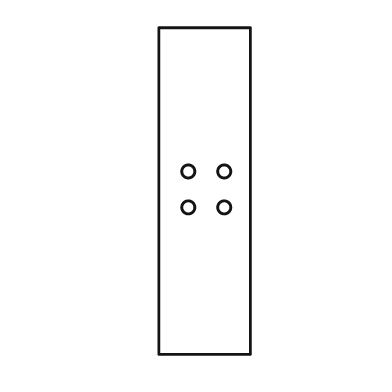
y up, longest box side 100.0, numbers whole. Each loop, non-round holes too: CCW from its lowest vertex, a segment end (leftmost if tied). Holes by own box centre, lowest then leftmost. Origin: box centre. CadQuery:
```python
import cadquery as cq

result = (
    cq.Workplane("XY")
    .moveTo(-14.0, -50.0)
    .lineTo(14.0, -50.0)
    .lineTo(14.0, 50.0)
    .lineTo(-14.0, 50.0)
    .close()
    .moveTo(-5.0, -5.0)
    .circle(2.0)
    .moveTo(6.0, -5.0)
    .circle(2.0)
    .moveTo(-5.0, 6.0)
    .circle(2.0)
    .moveTo(6.0, 6.0)
    .circle(2.0)
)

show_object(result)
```